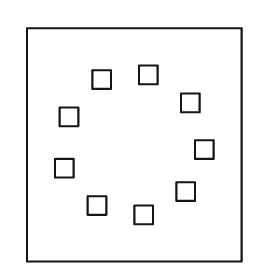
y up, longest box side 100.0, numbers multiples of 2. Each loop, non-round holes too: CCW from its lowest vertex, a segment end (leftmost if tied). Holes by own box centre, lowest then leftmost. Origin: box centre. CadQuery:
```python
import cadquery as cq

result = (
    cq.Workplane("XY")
    .moveTo(-46.0, -50.0)
    .lineTo(46.0, -50.0)
    .lineTo(46.0, 50.0)
    .lineTo(-46.0, 50.0)
    .close()
    .moveTo(0.0, -34.0)
    .lineTo(8.0, -34.0)
    .lineTo(8.0, -26.0)
    .lineTo(0.0, -26.0)
    .close()
    .moveTo(-20.0, -30.0)
    .lineTo(-12.0, -30.0)
    .lineTo(-12.0, -22.0)
    .lineTo(-20.0, -22.0)
    .close()
    .moveTo(18.0, -24.0)
    .lineTo(26.0, -24.0)
    .lineTo(26.0, -16.0)
    .lineTo(18.0, -16.0)
    .close()
    .moveTo(-34.0, -14.0)
    .lineTo(-26.0, -14.0)
    .lineTo(-26.0, -6.0)
    .lineTo(-34.0, -6.0)
    .close()
    .moveTo(26.0, -6.0)
    .lineTo(34.0, -6.0)
    .lineTo(34.0, 2.0)
    .lineTo(26.0, 2.0)
    .close()
    .moveTo(-32.0, 8.0)
    .lineTo(-24.0, 8.0)
    .lineTo(-24.0, 16.0)
    .lineTo(-32.0, 16.0)
    .close()
    .moveTo(20.0, 14.0)
    .lineTo(28.0, 14.0)
    .lineTo(28.0, 22.0)
    .lineTo(20.0, 22.0)
    .close()
    .moveTo(-18.0, 24.0)
    .lineTo(-10.0, 24.0)
    .lineTo(-10.0, 32.0)
    .lineTo(-18.0, 32.0)
    .close()
    .moveTo(2.0, 26.0)
    .lineTo(10.0, 26.0)
    .lineTo(10.0, 34.0)
    .lineTo(2.0, 34.0)
    .close()
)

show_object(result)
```